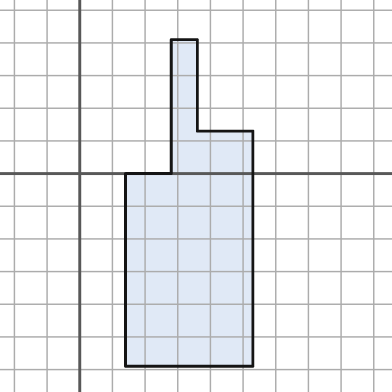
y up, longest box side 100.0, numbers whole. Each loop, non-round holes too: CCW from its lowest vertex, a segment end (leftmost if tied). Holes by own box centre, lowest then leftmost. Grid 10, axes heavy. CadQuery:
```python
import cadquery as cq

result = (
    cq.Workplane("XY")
    .moveTo(14.0, -59.0)
    .lineTo(53.0, -59.0)
    .lineTo(53.0, 13.0)
    .lineTo(36.0, 13.0)
    .lineTo(36.0, 41.0)
    .lineTo(28.0, 41.0)
    .lineTo(28.0, 0.0)
    .lineTo(14.0, 0.0)
    .close()
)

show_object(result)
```